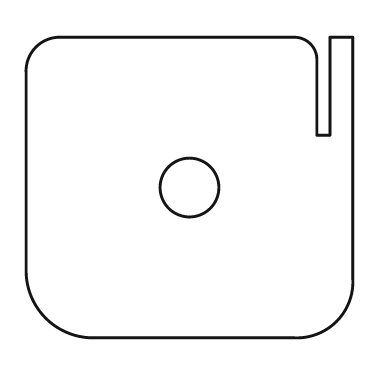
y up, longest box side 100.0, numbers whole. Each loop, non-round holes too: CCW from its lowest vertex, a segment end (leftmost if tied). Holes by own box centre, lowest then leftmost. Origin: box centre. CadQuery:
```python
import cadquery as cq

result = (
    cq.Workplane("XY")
    .moveTo(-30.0, -46.0)
    .lineTo(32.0, -46.0)
    .threePointArc((45.0, -41.0), (50.0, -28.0))
    .lineTo(50.0, 46.0)
    .lineTo(43.0, 46.0)
    .lineTo(43.0, 16.0)
    .lineTo(39.0, 16.0)
    .lineTo(39.0, 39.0)
    .threePointArc((37.0, 44.0), (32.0, 46.0))
    .lineTo(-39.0, 46.0)
    .threePointArc((-47.0, 43.0), (-50.0, 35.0))
    .lineTo(-50.0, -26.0)
    .threePointArc((-44.0, -40.0), (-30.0, -46.0))
    .close()
    .moveTo(0.0, 0.0)
    .circle(9.0)
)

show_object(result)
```